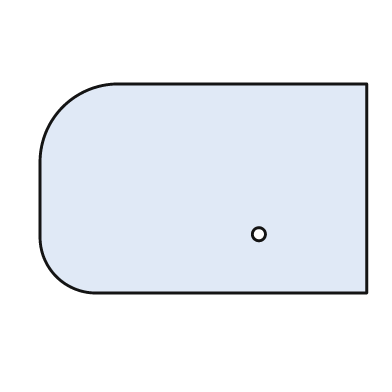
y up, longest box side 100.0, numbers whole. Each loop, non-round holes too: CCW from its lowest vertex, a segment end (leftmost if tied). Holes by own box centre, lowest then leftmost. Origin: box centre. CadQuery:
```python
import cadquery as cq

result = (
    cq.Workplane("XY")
    .moveTo(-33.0, -32.0)
    .lineTo(50.0, -32.0)
    .lineTo(50.0, 32.0)
    .lineTo(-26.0, 32.0)
    .threePointArc((-43.0, 25.0), (-50.0, 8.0))
    .lineTo(-50.0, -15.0)
    .threePointArc((-45.0, -27.0), (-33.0, -32.0))
    .close()
    .moveTo(17.0, -14.0)
    .circle(2.0)
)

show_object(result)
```